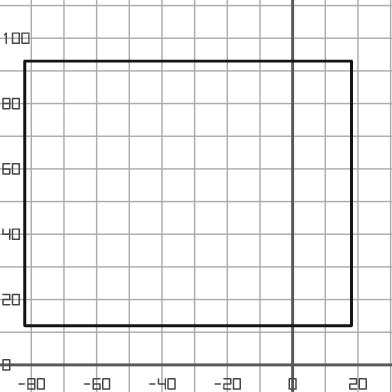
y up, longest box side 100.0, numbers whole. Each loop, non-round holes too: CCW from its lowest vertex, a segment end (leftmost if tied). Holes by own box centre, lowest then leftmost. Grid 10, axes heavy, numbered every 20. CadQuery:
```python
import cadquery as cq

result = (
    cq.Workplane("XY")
    .moveTo(-82.0, 12.0)
    .lineTo(18.0, 12.0)
    .lineTo(18.0, 93.0)
    .lineTo(-82.0, 93.0)
    .close()
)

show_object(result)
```